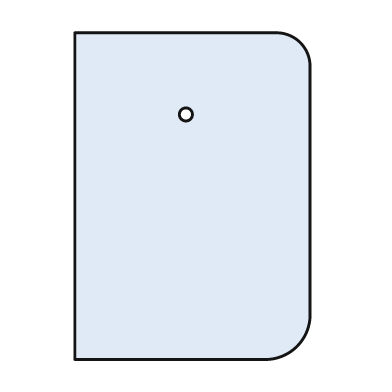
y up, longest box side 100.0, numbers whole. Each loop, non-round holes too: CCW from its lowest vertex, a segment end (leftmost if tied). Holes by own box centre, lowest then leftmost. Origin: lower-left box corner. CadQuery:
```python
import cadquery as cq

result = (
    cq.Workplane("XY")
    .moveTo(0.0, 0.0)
    .lineTo(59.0, 0.0)
    .threePointArc((68.0, 4.0), (72.0, 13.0))
    .lineTo(72.0, 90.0)
    .threePointArc((69.0, 97.0), (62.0, 100.0))
    .lineTo(0.0, 100.0)
    .close()
    .moveTo(34.0, 75.0)
    .circle(2.0)
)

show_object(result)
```